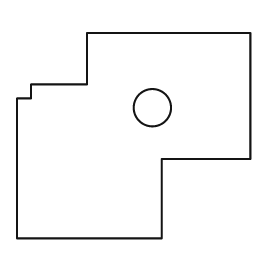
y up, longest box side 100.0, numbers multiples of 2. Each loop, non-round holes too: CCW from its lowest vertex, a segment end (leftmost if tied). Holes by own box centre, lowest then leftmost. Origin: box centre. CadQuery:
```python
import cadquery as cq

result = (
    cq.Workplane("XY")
    .moveTo(-50.0, -44.0)
    .lineTo(12.0, -44.0)
    .lineTo(12.0, -10.0)
    .lineTo(50.0, -10.0)
    .lineTo(50.0, 44.0)
    .lineTo(-20.0, 44.0)
    .lineTo(-20.0, 22.0)
    .lineTo(-44.0, 22.0)
    .lineTo(-44.0, 16.0)
    .lineTo(-50.0, 16.0)
    .close()
    .moveTo(8.0, 12.0)
    .circle(8.0)
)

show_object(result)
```